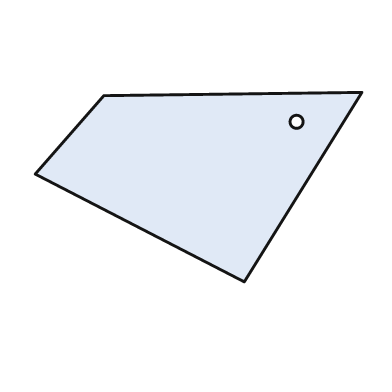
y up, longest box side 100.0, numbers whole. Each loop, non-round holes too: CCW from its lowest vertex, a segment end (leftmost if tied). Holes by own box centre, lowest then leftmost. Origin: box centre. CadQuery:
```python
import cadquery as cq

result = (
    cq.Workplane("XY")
    .moveTo(14.0, -29.0)
    .lineTo(50.0, 29.0)
    .lineTo(-29.0, 28.0)
    .lineTo(-50.0, 4.0)
    .close()
    .moveTo(30.0, 20.0)
    .circle(2.0)
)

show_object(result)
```